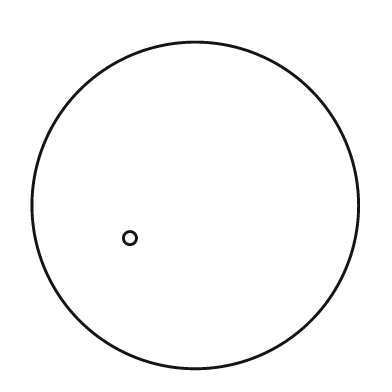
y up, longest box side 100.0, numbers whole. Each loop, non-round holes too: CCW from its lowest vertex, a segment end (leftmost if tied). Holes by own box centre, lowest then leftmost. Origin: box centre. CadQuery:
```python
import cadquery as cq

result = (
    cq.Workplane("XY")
    .moveTo(0.0, 0.0)
    .circle(50.0)
    .moveTo(-20.0, -10.0)
    .circle(2.0)
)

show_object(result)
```